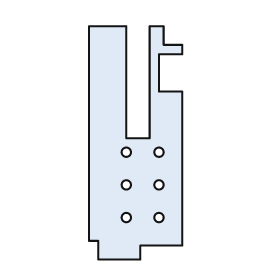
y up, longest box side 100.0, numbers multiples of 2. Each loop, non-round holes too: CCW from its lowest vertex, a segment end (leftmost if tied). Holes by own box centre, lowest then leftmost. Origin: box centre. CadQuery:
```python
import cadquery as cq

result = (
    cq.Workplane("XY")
    .moveTo(-16.0, -50.0)
    .lineTo(2.0, -50.0)
    .lineTo(2.0, -44.0)
    .lineTo(20.0, -44.0)
    .lineTo(20.0, 22.0)
    .lineTo(10.0, 22.0)
    .lineTo(10.0, 38.0)
    .lineTo(20.0, 38.0)
    .lineTo(20.0, 42.0)
    .lineTo(12.0, 42.0)
    .lineTo(12.0, 50.0)
    .lineTo(6.0, 50.0)
    .lineTo(6.0, 2.0)
    .lineTo(-4.0, 2.0)
    .lineTo(-4.0, 50.0)
    .lineTo(-20.0, 50.0)
    .lineTo(-20.0, -42.0)
    .lineTo(-16.0, -42.0)
    .close()
    .moveTo(-4.0, -32.0)
    .circle(2.0)
    .moveTo(10.0, -32.0)
    .circle(2.0)
    .moveTo(-4.0, -18.0)
    .circle(2.0)
    .moveTo(10.0, -18.0)
    .circle(2.0)
    .moveTo(-4.0, -4.0)
    .circle(2.0)
    .moveTo(10.0, -4.0)
    .circle(2.0)
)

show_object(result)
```